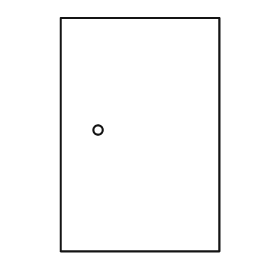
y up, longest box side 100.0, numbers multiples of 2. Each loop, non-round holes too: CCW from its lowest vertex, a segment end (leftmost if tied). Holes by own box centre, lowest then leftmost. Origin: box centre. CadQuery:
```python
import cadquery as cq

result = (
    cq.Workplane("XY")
    .moveTo(-34.0, -50.0)
    .lineTo(34.0, -50.0)
    .lineTo(34.0, 50.0)
    .lineTo(-34.0, 50.0)
    .close()
    .moveTo(-18.0, 2.0)
    .circle(2.0)
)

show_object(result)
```